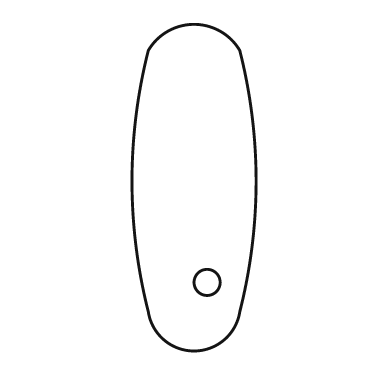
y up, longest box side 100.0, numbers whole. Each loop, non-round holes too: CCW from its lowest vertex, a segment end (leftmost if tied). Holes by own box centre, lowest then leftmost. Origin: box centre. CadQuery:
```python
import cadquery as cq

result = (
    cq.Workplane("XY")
    .moveTo(-14.0, -38.0)
    .threePointArc((0.0, -50.0), (14.0, -38.0))
    .threePointArc((19.0, 2.0), (14.0, 42.0))
    .threePointArc((0.0, 50.0), (-14.0, 42.0))
    .threePointArc((-19.0, 2.0), (-14.0, -38.0))
    .close()
    .moveTo(4.0, -29.0)
    .circle(4.0)
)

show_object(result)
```